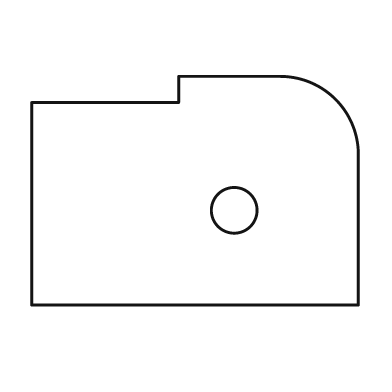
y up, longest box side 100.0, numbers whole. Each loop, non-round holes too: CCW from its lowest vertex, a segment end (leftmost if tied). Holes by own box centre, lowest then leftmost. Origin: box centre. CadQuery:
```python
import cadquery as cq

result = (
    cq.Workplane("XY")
    .moveTo(-50.0, -35.0)
    .lineTo(50.0, -35.0)
    .lineTo(50.0, 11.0)
    .threePointArc((43.0, 28.0), (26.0, 35.0))
    .lineTo(-5.0, 35.0)
    .lineTo(-5.0, 27.0)
    .lineTo(-50.0, 27.0)
    .close()
    .moveTo(12.0, -6.0)
    .circle(7.0)
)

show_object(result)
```